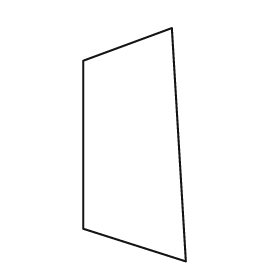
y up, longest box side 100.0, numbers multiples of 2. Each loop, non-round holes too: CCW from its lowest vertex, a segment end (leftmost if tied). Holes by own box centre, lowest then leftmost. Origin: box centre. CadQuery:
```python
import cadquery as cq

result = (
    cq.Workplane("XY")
    .moveTo(22.0, -50.0)
    .lineTo(16.0, 50.0)
    .lineTo(-22.0, 36.0)
    .lineTo(-22.0, -36.0)
    .close()
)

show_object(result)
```